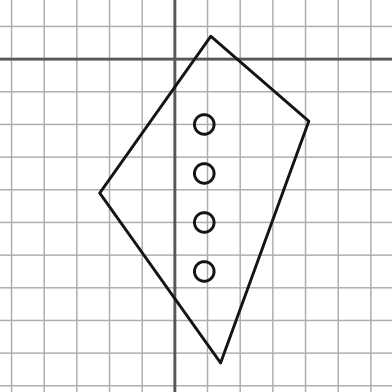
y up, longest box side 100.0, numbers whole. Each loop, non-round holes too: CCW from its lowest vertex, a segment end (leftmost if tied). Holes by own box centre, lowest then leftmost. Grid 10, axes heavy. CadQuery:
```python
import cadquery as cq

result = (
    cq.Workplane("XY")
    .moveTo(14.0, -93.0)
    .lineTo(41.0, -19.0)
    .lineTo(11.0, 7.0)
    .lineTo(-23.0, -41.0)
    .close()
    .moveTo(9.0, -65.0)
    .circle(3.0)
    .moveTo(9.0, -50.0)
    .circle(3.0)
    .moveTo(9.0, -35.0)
    .circle(3.0)
    .moveTo(9.0, -20.0)
    .circle(3.0)
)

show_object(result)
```